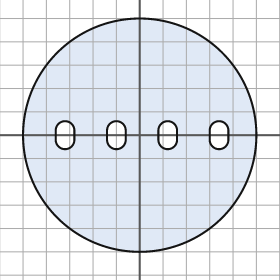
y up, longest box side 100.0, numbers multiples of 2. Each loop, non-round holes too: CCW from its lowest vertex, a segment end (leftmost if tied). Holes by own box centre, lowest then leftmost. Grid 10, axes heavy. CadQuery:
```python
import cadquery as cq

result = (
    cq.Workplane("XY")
    .moveTo(0.0, 0.0)
    .circle(50.0)
    .moveTo(-36.0, -2.0)
    .threePointArc((-32.0, -6.0), (-28.0, -2.0))
    .lineTo(-28.0, 2.0)
    .threePointArc((-32.0, 6.0), (-36.0, 2.0))
    .close()
    .moveTo(-14.0, -2.0)
    .threePointArc((-10.0, -6.0), (-6.0, -2.0))
    .lineTo(-6.0, 2.0)
    .threePointArc((-10.0, 6.0), (-14.0, 2.0))
    .close()
    .moveTo(8.0, -2.0)
    .threePointArc((12.0, -6.0), (16.0, -2.0))
    .lineTo(16.0, 2.0)
    .threePointArc((12.0, 6.0), (8.0, 2.0))
    .close()
    .moveTo(30.0, -2.0)
    .threePointArc((34.0, -6.0), (38.0, -2.0))
    .lineTo(38.0, 2.0)
    .threePointArc((34.0, 6.0), (30.0, 2.0))
    .close()
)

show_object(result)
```